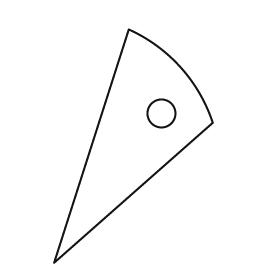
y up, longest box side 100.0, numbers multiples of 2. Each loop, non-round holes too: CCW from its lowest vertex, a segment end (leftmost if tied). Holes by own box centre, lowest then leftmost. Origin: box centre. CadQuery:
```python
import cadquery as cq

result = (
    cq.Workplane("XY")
    .moveTo(-34.0, -50.0)
    .lineTo(34.0, 10.0)
    .threePointArc((20.0, 34.0), (-2.0, 50.0))
    .close()
    .moveTo(12.0, 14.0)
    .circle(6.0)
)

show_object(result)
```